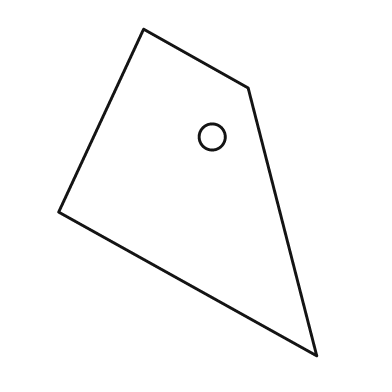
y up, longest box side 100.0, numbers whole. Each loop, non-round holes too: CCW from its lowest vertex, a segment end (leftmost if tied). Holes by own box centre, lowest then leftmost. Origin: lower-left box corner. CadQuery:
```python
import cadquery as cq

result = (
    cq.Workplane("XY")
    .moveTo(79.0, 0.0)
    .lineTo(58.0, 82.0)
    .lineTo(26.0, 100.0)
    .lineTo(0.0, 44.0)
    .close()
    .moveTo(47.0, 67.0)
    .circle(4.0)
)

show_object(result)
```